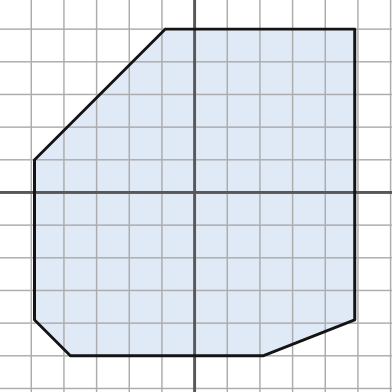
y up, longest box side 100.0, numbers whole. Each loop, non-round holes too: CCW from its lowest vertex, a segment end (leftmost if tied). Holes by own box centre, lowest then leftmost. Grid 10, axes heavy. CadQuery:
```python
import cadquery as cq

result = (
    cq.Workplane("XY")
    .moveTo(-38.0, -50.0)
    .lineTo(21.0, -50.0)
    .lineTo(49.0, -39.0)
    .lineTo(49.0, 50.0)
    .lineTo(-9.0, 50.0)
    .lineTo(-49.0, 10.0)
    .lineTo(-49.0, -39.0)
    .close()
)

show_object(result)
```